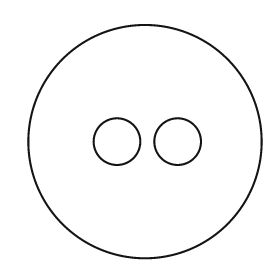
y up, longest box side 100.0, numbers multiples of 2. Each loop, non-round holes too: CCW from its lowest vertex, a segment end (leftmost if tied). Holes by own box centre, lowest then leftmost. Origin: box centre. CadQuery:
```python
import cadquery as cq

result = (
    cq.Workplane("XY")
    .moveTo(0.0, 0.0)
    .circle(50.0)
    .moveTo(-12.0, 0.0)
    .circle(10.0)
    .moveTo(14.0, 0.0)
    .circle(10.0)
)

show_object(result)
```